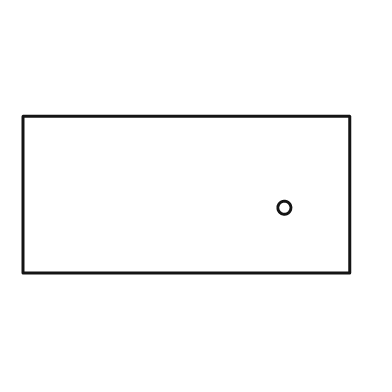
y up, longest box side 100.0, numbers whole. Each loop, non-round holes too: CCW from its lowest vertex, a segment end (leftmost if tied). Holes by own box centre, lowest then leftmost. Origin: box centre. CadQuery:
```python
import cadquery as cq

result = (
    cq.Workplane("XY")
    .moveTo(-50.0, -24.0)
    .lineTo(50.0, -24.0)
    .lineTo(50.0, 24.0)
    .lineTo(-50.0, 24.0)
    .close()
    .moveTo(30.0, -4.0)
    .circle(2.0)
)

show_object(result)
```